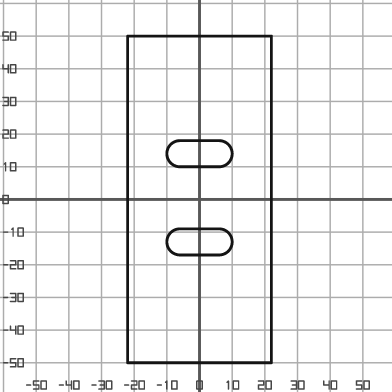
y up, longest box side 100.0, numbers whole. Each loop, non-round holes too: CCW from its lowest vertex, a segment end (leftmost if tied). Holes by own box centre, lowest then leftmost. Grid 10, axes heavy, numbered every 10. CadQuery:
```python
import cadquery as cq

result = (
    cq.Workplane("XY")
    .moveTo(-22.0, -50.0)
    .lineTo(22.0, -50.0)
    .lineTo(22.0, 50.0)
    .lineTo(-22.0, 50.0)
    .close()
    .moveTo(-6.0, -17.0)
    .lineTo(6.0, -17.0)
    .threePointArc((10.0, -13.0), (6.0, -9.0))
    .lineTo(-6.0, -9.0)
    .threePointArc((-10.0, -13.0), (-6.0, -17.0))
    .close()
    .moveTo(-6.0, 10.0)
    .lineTo(6.0, 10.0)
    .threePointArc((10.0, 14.0), (6.0, 18.0))
    .lineTo(-6.0, 18.0)
    .threePointArc((-10.0, 14.0), (-6.0, 10.0))
    .close()
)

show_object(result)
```